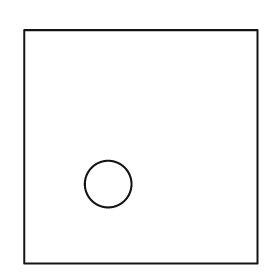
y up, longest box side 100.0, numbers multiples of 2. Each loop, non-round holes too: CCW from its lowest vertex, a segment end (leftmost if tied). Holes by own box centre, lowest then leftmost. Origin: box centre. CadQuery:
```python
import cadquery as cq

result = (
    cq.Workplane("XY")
    .moveTo(-50.0, -50.0)
    .lineTo(50.0, -50.0)
    .lineTo(50.0, 50.0)
    .lineTo(-50.0, 50.0)
    .close()
    .moveTo(-14.0, -16.0)
    .circle(10.0)
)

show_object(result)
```